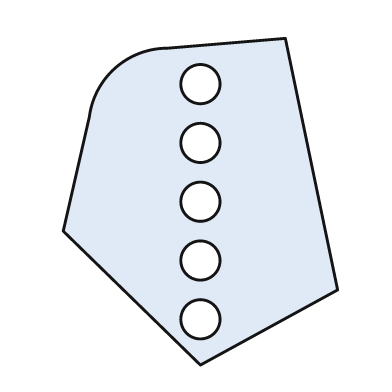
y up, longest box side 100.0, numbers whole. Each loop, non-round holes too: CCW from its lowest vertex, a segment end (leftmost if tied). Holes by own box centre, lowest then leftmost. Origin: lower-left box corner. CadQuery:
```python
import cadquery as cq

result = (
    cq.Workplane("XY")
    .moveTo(42.0, 0.0)
    .lineTo(84.0, 23.0)
    .lineTo(68.0, 100.0)
    .lineTo(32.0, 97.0)
    .threePointArc((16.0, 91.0), (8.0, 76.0))
    .lineTo(0.0, 41.0)
    .close()
    .moveTo(42.0, 14.0)
    .circle(6.0)
    .moveTo(42.0, 32.0)
    .circle(6.0)
    .moveTo(42.0, 50.0)
    .circle(6.0)
    .moveTo(42.0, 68.0)
    .circle(6.0)
    .moveTo(42.0, 86.0)
    .circle(6.0)
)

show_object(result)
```